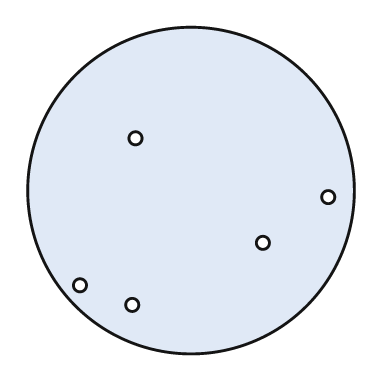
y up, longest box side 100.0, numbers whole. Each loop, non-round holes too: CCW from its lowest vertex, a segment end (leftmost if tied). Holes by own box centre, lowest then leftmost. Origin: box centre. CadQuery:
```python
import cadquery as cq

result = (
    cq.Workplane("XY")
    .moveTo(0.0, 0.0)
    .circle(50.0)
    .moveTo(-18.0, -35.0)
    .circle(2.0)
    .moveTo(-34.0, -29.0)
    .circle(2.0)
    .moveTo(22.0, -16.0)
    .circle(2.0)
    .moveTo(42.0, -2.0)
    .circle(2.0)
    .moveTo(-17.0, 16.0)
    .circle(2.0)
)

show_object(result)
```